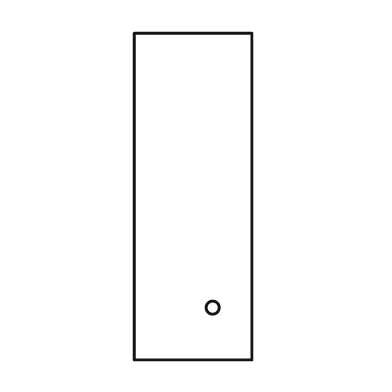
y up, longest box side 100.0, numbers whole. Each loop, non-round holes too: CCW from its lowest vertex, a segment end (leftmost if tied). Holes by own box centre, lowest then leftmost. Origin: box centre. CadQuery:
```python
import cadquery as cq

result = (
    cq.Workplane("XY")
    .moveTo(-18.0, -50.0)
    .lineTo(18.0, -50.0)
    .lineTo(18.0, 50.0)
    .lineTo(-18.0, 50.0)
    .close()
    .moveTo(6.0, -34.0)
    .circle(2.0)
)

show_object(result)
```